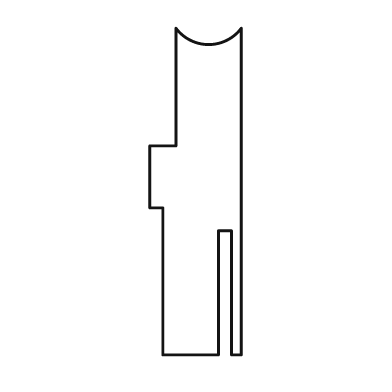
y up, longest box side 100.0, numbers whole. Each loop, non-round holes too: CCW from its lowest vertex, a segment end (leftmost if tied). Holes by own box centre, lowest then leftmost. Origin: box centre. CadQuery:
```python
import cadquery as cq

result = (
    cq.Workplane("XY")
    .moveTo(-10.0, -50.0)
    .lineTo(7.0, -50.0)
    .lineTo(7.0, -12.0)
    .lineTo(11.0, -12.0)
    .lineTo(11.0, -50.0)
    .lineTo(14.0, -50.0)
    .lineTo(14.0, 50.0)
    .threePointArc((4.0, 45.0), (-6.0, 50.0))
    .lineTo(-6.0, 14.0)
    .lineTo(-14.0, 14.0)
    .lineTo(-14.0, -5.0)
    .lineTo(-10.0, -5.0)
    .close()
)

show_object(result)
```